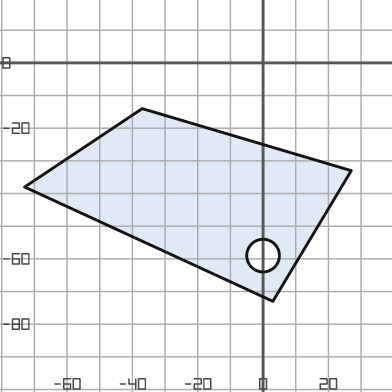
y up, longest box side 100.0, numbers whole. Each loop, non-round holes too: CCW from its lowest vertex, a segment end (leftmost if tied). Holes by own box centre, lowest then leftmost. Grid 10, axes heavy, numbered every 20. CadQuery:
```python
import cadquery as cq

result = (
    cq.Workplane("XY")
    .moveTo(3.0, -73.0)
    .lineTo(27.0, -33.0)
    .lineTo(-37.0, -14.0)
    .lineTo(-73.0, -38.0)
    .close()
    .moveTo(0.0, -59.0)
    .circle(5.0)
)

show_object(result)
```